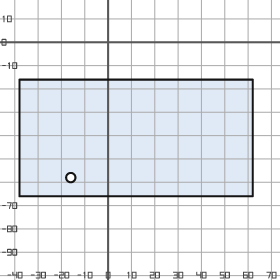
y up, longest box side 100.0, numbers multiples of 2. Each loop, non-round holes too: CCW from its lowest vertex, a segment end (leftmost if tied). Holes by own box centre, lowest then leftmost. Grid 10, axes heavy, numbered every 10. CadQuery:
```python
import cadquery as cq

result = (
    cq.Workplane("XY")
    .moveTo(-38.0, -66.0)
    .lineTo(62.0, -66.0)
    .lineTo(62.0, -16.0)
    .lineTo(-38.0, -16.0)
    .close()
    .moveTo(-16.0, -58.0)
    .circle(2.0)
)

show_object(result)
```